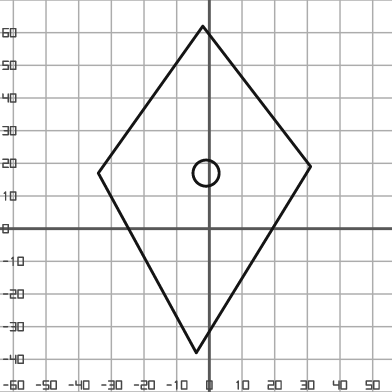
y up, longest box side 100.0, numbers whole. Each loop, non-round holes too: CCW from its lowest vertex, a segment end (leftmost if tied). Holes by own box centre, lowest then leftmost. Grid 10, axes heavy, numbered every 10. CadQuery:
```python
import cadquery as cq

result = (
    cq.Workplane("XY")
    .moveTo(-4.0, -38.0)
    .lineTo(31.0, 19.0)
    .lineTo(-2.0, 62.0)
    .lineTo(-34.0, 17.0)
    .close()
    .moveTo(-1.0, 17.0)
    .circle(4.0)
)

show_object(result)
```